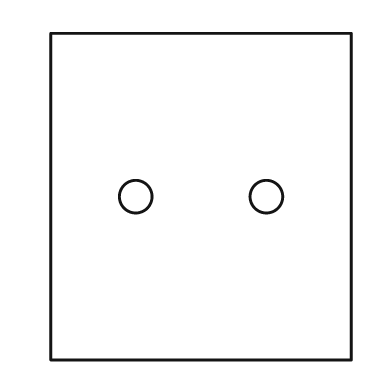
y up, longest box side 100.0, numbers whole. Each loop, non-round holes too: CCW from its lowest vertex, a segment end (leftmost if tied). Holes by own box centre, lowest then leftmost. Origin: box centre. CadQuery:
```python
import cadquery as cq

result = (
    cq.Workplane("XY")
    .moveTo(-46.0, -50.0)
    .lineTo(46.0, -50.0)
    .lineTo(46.0, 50.0)
    .lineTo(-46.0, 50.0)
    .close()
    .moveTo(-20.0, 0.0)
    .circle(5.0)
    .moveTo(20.0, 0.0)
    .circle(5.0)
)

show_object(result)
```